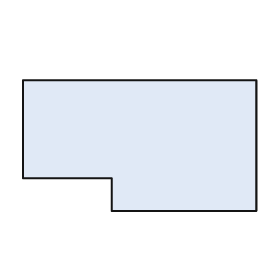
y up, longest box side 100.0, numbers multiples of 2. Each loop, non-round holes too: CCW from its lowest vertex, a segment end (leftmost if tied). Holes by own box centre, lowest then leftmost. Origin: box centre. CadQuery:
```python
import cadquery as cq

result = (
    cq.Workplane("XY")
    .moveTo(-12.0, -28.0)
    .lineTo(50.0, -28.0)
    .lineTo(50.0, 28.0)
    .lineTo(-50.0, 28.0)
    .lineTo(-50.0, -14.0)
    .lineTo(-12.0, -14.0)
    .close()
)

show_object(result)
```